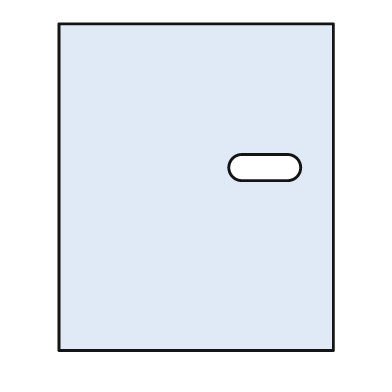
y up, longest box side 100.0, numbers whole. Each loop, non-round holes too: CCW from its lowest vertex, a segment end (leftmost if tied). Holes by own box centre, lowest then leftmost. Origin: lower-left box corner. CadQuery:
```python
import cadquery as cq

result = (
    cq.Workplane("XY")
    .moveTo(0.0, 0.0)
    .lineTo(84.0, 0.0)
    .lineTo(84.0, 100.0)
    .lineTo(0.0, 100.0)
    .close()
    .moveTo(56.0, 52.0)
    .lineTo(70.0, 52.0)
    .threePointArc((74.0, 56.0), (70.0, 60.0))
    .lineTo(56.0, 60.0)
    .threePointArc((52.0, 56.0), (56.0, 52.0))
    .close()
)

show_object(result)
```